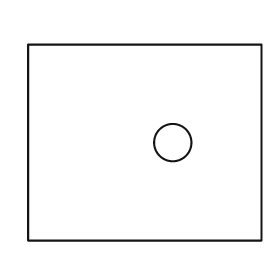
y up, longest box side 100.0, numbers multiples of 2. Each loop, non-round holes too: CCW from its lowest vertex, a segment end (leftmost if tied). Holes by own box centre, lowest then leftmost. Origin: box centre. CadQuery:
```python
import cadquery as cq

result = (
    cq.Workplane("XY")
    .moveTo(-50.0, -42.0)
    .lineTo(50.0, -42.0)
    .lineTo(50.0, 42.0)
    .lineTo(-50.0, 42.0)
    .close()
    .moveTo(12.0, 0.0)
    .circle(8.0)
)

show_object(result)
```